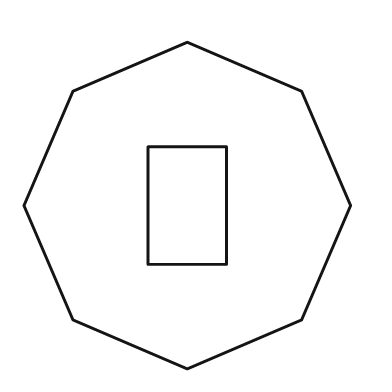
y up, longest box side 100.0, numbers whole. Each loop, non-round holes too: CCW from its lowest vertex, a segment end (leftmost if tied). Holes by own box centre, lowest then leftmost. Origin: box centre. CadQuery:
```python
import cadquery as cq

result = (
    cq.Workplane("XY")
    .moveTo(0.0, -50.0)
    .lineTo(35.0, -35.0)
    .lineTo(50.0, 0.0)
    .lineTo(35.0, 35.0)
    .lineTo(0.0, 50.0)
    .lineTo(-35.0, 35.0)
    .lineTo(-50.0, 0.0)
    .lineTo(-35.0, -35.0)
    .close()
    .moveTo(-12.0, -18.0)
    .lineTo(12.0, -18.0)
    .lineTo(12.0, 18.0)
    .lineTo(-12.0, 18.0)
    .close()
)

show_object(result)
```